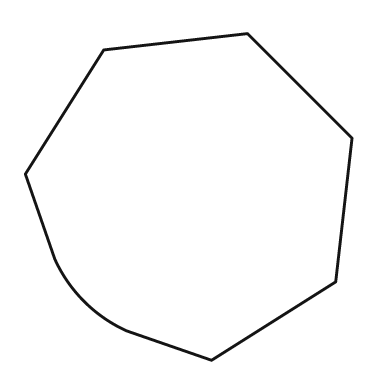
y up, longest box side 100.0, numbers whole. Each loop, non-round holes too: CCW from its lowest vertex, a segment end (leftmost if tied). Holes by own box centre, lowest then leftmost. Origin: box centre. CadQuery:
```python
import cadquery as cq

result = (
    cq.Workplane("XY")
    .moveTo(7.0, -50.0)
    .lineTo(45.0, -26.0)
    .lineTo(50.0, 18.0)
    .lineTo(18.0, 50.0)
    .lineTo(-26.0, 45.0)
    .lineTo(-50.0, 7.0)
    .lineTo(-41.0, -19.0)
    .threePointArc((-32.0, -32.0), (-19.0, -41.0))
    .close()
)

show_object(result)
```